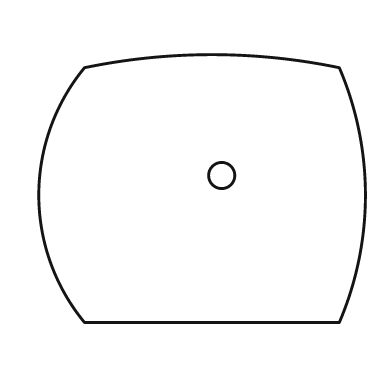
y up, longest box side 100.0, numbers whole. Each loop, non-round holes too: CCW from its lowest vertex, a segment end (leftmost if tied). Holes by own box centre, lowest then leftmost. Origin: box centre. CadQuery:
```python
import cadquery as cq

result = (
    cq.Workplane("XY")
    .moveTo(-36.0, -41.0)
    .lineTo(42.0, -41.0)
    .threePointArc((50.0, -2.0), (42.0, 37.0))
    .threePointArc((3.0, 41.0), (-36.0, 37.0))
    .threePointArc((-50.0, -2.0), (-36.0, -41.0))
    .close()
    .moveTo(6.0, 4.0)
    .circle(4.0)
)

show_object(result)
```